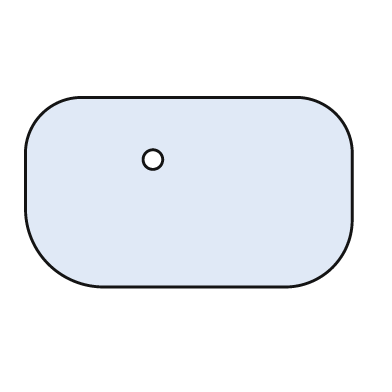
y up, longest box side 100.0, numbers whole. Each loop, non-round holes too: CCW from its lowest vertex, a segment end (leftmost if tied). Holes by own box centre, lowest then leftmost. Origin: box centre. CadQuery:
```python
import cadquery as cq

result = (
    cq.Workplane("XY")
    .moveTo(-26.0, -29.0)
    .lineTo(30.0, -29.0)
    .threePointArc((44.0, -23.0), (50.0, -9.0))
    .lineTo(50.0, 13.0)
    .threePointArc((45.0, 24.0), (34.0, 29.0))
    .lineTo(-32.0, 29.0)
    .threePointArc((-45.0, 24.0), (-50.0, 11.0))
    .lineTo(-50.0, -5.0)
    .threePointArc((-43.0, -22.0), (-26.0, -29.0))
    .close()
    .moveTo(-11.0, 10.0)
    .circle(3.0)
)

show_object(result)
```